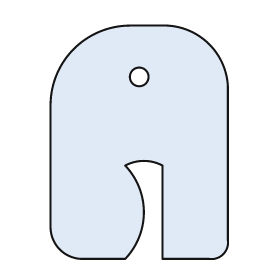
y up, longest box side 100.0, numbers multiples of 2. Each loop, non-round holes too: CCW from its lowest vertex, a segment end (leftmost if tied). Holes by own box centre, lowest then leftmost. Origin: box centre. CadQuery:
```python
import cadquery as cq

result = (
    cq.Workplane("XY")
    .moveTo(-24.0, -50.0)
    .lineTo(-6.0, -50.0)
    .threePointArc((2.0, -30.0), (-6.0, -10.0))
    .threePointArc((2.0, -8.0), (10.0, -10.0))
    .lineTo(10.0, -50.0)
    .lineTo(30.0, -50.0)
    .threePointArc((36.0, -48.0), (38.0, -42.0))
    .lineTo(38.0, 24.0)
    .threePointArc((30.0, 42.0), (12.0, 50.0))
    .lineTo(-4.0, 50.0)
    .threePointArc((-28.0, 40.0), (-38.0, 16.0))
    .lineTo(-38.0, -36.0)
    .threePointArc((-34.0, -46.0), (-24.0, -50.0))
    .close()
    .moveTo(0.0, 28.0)
    .circle(4.0)
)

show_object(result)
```